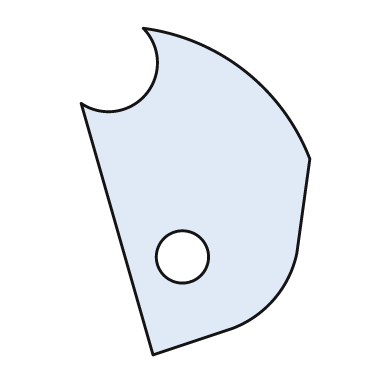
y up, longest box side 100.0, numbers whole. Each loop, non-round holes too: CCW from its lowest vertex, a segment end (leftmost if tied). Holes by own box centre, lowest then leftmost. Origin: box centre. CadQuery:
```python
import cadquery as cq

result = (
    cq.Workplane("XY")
    .moveTo(-13.0, -50.0)
    .lineTo(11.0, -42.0)
    .threePointArc((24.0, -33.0), (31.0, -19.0))
    .lineTo(35.0, 10.0)
    .threePointArc((15.0, 37.0), (-16.0, 50.0))
    .threePointArc((-15.0, 30.0), (-35.0, 27.0))
    .close()
    .moveTo(-4.0, -20.0)
    .circle(8.0)
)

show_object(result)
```